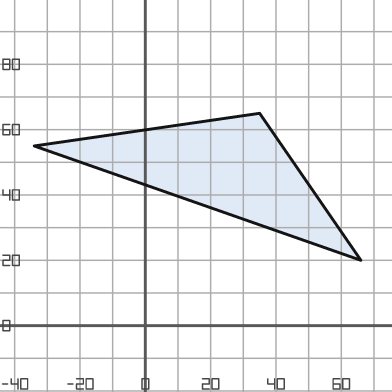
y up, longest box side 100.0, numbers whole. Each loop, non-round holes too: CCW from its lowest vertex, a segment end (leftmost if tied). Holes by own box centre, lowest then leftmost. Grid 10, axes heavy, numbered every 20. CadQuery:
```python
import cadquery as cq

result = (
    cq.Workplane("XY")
    .moveTo(66.0, 20.0)
    .lineTo(35.0, 65.0)
    .lineTo(-34.0, 55.0)
    .close()
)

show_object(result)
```